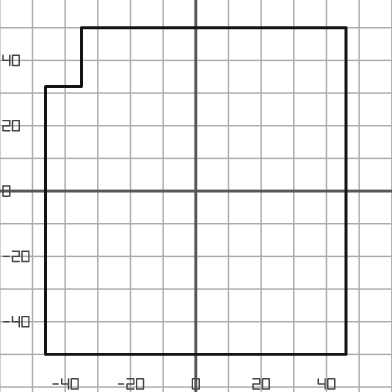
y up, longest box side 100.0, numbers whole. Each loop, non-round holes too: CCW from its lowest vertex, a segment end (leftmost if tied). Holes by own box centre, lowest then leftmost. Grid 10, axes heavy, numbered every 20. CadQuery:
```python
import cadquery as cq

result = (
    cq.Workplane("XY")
    .moveTo(-46.0, -50.0)
    .lineTo(46.0, -50.0)
    .lineTo(46.0, 50.0)
    .lineTo(-35.0, 50.0)
    .lineTo(-35.0, 32.0)
    .lineTo(-46.0, 32.0)
    .close()
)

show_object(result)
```